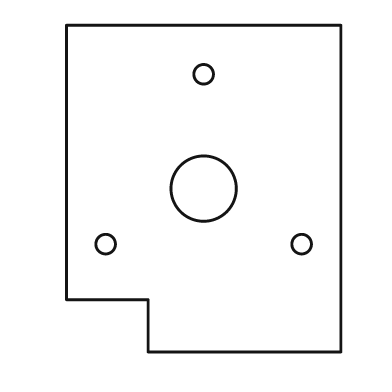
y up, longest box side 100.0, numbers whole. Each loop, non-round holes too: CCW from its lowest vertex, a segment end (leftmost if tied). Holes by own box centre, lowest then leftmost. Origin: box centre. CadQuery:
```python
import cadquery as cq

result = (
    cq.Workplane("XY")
    .moveTo(-17.0, -50.0)
    .lineTo(42.0, -50.0)
    .lineTo(42.0, 50.0)
    .lineTo(-42.0, 50.0)
    .lineTo(-42.0, -34.0)
    .lineTo(-17.0, -34.0)
    .close()
    .moveTo(-30.0, -17.0)
    .circle(3.0)
    .moveTo(30.0, -17.0)
    .circle(3.0)
    .moveTo(0.0, 0.0)
    .circle(10.0)
    .moveTo(0.0, 35.0)
    .circle(3.0)
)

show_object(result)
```